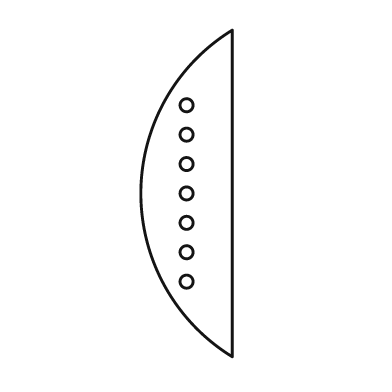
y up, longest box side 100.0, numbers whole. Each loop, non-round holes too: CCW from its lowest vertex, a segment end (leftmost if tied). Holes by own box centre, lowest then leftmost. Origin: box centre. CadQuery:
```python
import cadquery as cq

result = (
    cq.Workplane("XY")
    .moveTo(14.0, -50.0)
    .lineTo(14.0, 50.0)
    .threePointArc((-14.0, 0.0), (14.0, -50.0))
    .close()
    .moveTo(0.0, -27.0)
    .circle(2.0)
    .moveTo(0.0, -18.0)
    .circle(2.0)
    .moveTo(0.0, -9.0)
    .circle(2.0)
    .moveTo(0.0, 0.0)
    .circle(2.0)
    .moveTo(0.0, 9.0)
    .circle(2.0)
    .moveTo(0.0, 18.0)
    .circle(2.0)
    .moveTo(0.0, 27.0)
    .circle(2.0)
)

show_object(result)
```